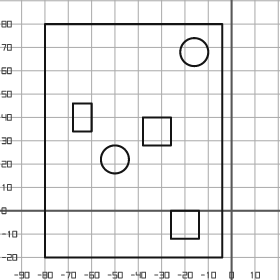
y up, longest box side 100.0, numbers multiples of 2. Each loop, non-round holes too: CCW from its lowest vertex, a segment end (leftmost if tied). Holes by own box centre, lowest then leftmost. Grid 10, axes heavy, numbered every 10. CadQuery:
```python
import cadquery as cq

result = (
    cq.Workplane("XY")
    .moveTo(-80.0, -20.0)
    .lineTo(-4.0, -20.0)
    .lineTo(-4.0, 80.0)
    .lineTo(-80.0, 80.0)
    .close()
    .moveTo(-26.0, -12.0)
    .lineTo(-14.0, -12.0)
    .lineTo(-14.0, 0.0)
    .lineTo(-26.0, 0.0)
    .close()
    .moveTo(-50.0, 22.0)
    .circle(6.0)
    .moveTo(-38.0, 28.0)
    .lineTo(-26.0, 28.0)
    .lineTo(-26.0, 40.0)
    .lineTo(-38.0, 40.0)
    .close()
    .moveTo(-68.0, 34.0)
    .lineTo(-60.0, 34.0)
    .lineTo(-60.0, 46.0)
    .lineTo(-68.0, 46.0)
    .close()
    .moveTo(-16.0, 68.0)
    .circle(6.0)
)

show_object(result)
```